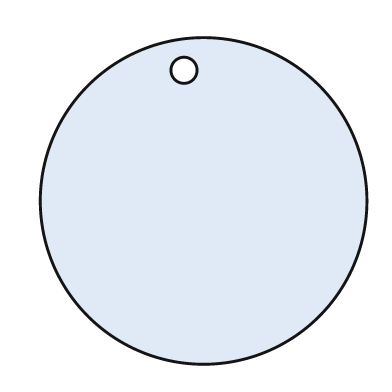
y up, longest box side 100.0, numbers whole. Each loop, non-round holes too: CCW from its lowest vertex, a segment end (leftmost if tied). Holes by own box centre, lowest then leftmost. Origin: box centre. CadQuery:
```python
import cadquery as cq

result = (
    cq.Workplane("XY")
    .moveTo(0.0, 0.0)
    .circle(50.0)
    .moveTo(-6.0, 40.0)
    .circle(4.0)
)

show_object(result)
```